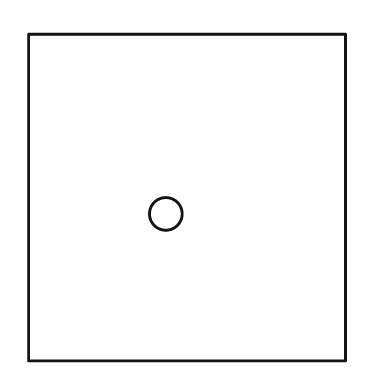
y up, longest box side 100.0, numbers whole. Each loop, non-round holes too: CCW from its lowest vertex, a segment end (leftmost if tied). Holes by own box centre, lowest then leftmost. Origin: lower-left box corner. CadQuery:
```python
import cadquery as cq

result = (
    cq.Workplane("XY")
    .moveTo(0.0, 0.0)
    .lineTo(97.0, 0.0)
    .lineTo(97.0, 100.0)
    .lineTo(0.0, 100.0)
    .close()
    .moveTo(42.0, 45.0)
    .circle(5.0)
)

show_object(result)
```